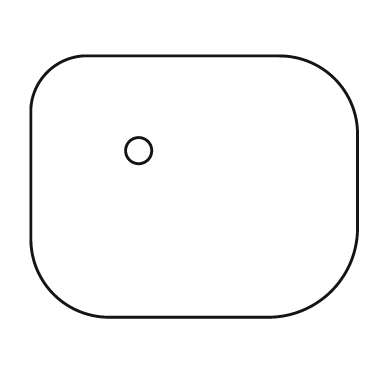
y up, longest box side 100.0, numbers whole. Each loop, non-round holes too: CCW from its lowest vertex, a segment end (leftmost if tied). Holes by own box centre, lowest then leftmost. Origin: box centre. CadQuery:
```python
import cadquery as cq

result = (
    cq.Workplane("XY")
    .moveTo(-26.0, -40.0)
    .lineTo(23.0, -40.0)
    .threePointArc((42.0, -32.0), (50.0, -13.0))
    .lineTo(50.0, 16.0)
    .threePointArc((43.0, 33.0), (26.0, 40.0))
    .lineTo(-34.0, 40.0)
    .threePointArc((-45.0, 35.0), (-50.0, 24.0))
    .lineTo(-50.0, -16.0)
    .threePointArc((-43.0, -33.0), (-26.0, -40.0))
    .close()
    .moveTo(-17.0, 11.0)
    .circle(4.0)
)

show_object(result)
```